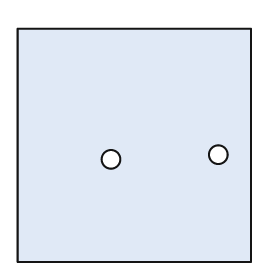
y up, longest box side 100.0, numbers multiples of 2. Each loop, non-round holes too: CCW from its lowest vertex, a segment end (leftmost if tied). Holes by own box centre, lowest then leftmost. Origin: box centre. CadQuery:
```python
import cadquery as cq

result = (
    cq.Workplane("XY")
    .moveTo(-50.0, -50.0)
    .lineTo(50.0, -50.0)
    .lineTo(50.0, 50.0)
    .lineTo(-50.0, 50.0)
    .close()
    .moveTo(-10.0, -6.0)
    .circle(4.0)
    .moveTo(36.0, -4.0)
    .circle(4.0)
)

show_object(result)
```